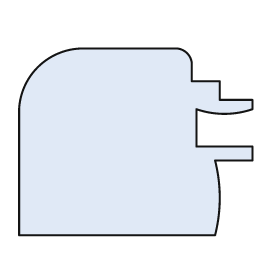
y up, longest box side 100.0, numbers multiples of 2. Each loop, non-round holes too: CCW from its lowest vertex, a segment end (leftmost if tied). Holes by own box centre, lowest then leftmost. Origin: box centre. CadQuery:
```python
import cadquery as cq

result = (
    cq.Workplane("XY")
    .moveTo(-50.0, -40.0)
    .lineTo(34.0, -40.0)
    .threePointArc((36.0, -24.0), (34.0, -8.0))
    .lineTo(50.0, -8.0)
    .lineTo(50.0, -2.0)
    .lineTo(26.0, -2.0)
    .lineTo(26.0, 14.0)
    .threePointArc((38.0, 12.0), (50.0, 14.0))
    .lineTo(50.0, 18.0)
    .lineTo(36.0, 18.0)
    .lineTo(36.0, 26.0)
    .lineTo(24.0, 26.0)
    .lineTo(24.0, 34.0)
    .threePointArc((22.0, 38.0), (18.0, 40.0))
    .lineTo(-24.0, 40.0)
    .threePointArc((-42.0, 32.0), (-50.0, 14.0))
    .close()
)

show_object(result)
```